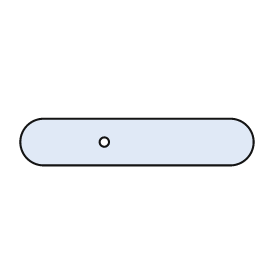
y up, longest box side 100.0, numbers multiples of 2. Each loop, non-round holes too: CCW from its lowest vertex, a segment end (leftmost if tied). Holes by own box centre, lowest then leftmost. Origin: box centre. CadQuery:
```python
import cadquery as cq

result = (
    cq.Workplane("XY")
    .moveTo(-40.0, -10.0)
    .lineTo(40.0, -10.0)
    .threePointArc((50.0, 0.0), (40.0, 10.0))
    .lineTo(-40.0, 10.0)
    .threePointArc((-50.0, 0.0), (-40.0, -10.0))
    .close()
    .moveTo(-14.0, 0.0)
    .circle(2.0)
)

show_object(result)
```